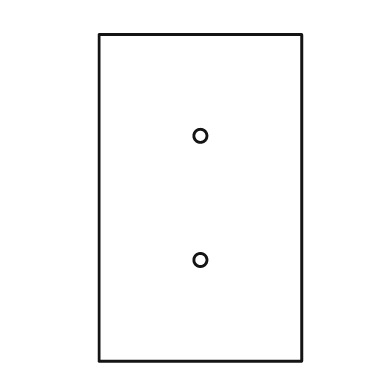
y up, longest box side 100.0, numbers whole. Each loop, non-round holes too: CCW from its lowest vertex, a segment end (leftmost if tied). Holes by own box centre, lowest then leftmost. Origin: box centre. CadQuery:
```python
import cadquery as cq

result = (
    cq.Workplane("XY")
    .moveTo(-31.0, -50.0)
    .lineTo(31.0, -50.0)
    .lineTo(31.0, 50.0)
    .lineTo(-31.0, 50.0)
    .close()
    .moveTo(0.0, -19.0)
    .circle(2.0)
    .moveTo(0.0, 19.0)
    .circle(2.0)
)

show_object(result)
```